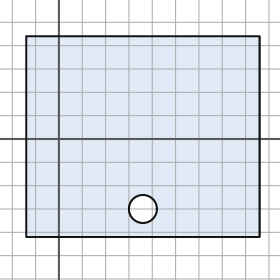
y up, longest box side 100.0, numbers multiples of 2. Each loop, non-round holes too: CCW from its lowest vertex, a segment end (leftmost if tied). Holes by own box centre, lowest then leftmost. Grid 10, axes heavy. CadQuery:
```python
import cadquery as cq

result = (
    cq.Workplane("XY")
    .moveTo(-14.0, -42.0)
    .lineTo(86.0, -42.0)
    .lineTo(86.0, 44.0)
    .lineTo(-14.0, 44.0)
    .close()
    .moveTo(36.0, -30.0)
    .circle(6.0)
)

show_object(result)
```